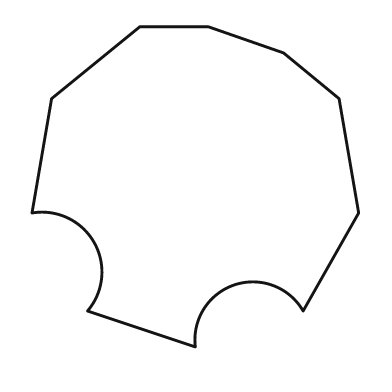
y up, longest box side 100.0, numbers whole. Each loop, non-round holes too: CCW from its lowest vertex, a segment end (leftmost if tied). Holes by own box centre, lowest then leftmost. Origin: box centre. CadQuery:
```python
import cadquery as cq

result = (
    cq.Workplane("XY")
    .moveTo(0.0, -49.0)
    .threePointArc((12.0, -30.0), (33.0, -38.0))
    .lineTo(50.0, -8.0)
    .lineTo(44.0, 27.0)
    .lineTo(27.0, 41.0)
    .lineTo(4.0, 49.0)
    .lineTo(-17.0, 49.0)
    .lineTo(-44.0, 27.0)
    .lineTo(-50.0, -8.0)
    .threePointArc((-31.0, -17.0), (-33.0, -38.0))
    .close()
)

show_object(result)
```